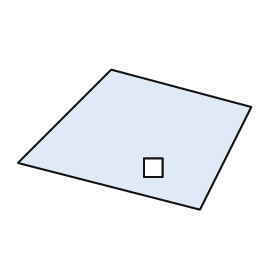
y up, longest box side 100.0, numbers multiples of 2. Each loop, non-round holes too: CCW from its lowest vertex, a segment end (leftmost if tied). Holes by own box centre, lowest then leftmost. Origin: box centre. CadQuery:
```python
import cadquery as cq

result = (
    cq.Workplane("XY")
    .moveTo(28.0, -30.0)
    .lineTo(50.0, 14.0)
    .lineTo(-10.0, 30.0)
    .lineTo(-50.0, -10.0)
    .close()
    .moveTo(4.0, -16.0)
    .lineTo(12.0, -16.0)
    .lineTo(12.0, -8.0)
    .lineTo(4.0, -8.0)
    .close()
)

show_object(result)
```